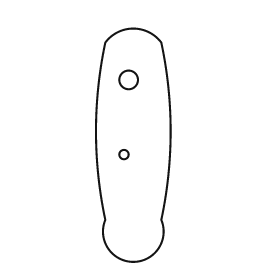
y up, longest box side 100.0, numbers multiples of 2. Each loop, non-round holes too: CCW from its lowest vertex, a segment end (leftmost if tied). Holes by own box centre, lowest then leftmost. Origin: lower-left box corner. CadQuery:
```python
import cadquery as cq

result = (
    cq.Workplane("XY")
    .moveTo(4.0, 18.0)
    .threePointArc((16.0, 0.0), (28.0, 18.0))
    .threePointArc((32.0, 56.0), (28.0, 94.0))
    .threePointArc((16.0, 100.0), (4.0, 94.0))
    .threePointArc((0.0, 56.0), (4.0, 18.0))
    .close()
    .moveTo(12.0, 46.0)
    .circle(2.0)
    .moveTo(14.0, 78.0)
    .circle(4.0)
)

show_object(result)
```